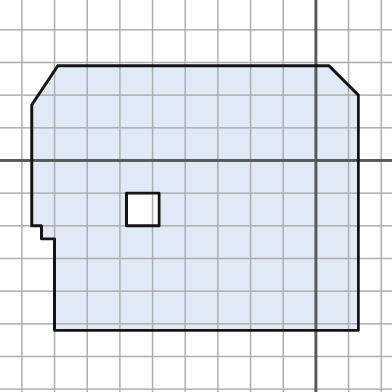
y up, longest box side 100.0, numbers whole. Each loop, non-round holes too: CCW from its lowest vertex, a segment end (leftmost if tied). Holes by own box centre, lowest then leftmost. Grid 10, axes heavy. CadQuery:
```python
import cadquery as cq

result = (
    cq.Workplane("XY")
    .moveTo(-80.0, -52.0)
    .lineTo(13.0, -52.0)
    .lineTo(13.0, 20.0)
    .lineTo(4.0, 29.0)
    .lineTo(-79.0, 29.0)
    .lineTo(-87.0, 17.0)
    .lineTo(-87.0, -20.0)
    .lineTo(-84.0, -20.0)
    .lineTo(-84.0, -24.0)
    .lineTo(-80.0, -24.0)
    .close()
    .moveTo(-58.0, -20.0)
    .lineTo(-48.0, -20.0)
    .lineTo(-48.0, -10.0)
    .lineTo(-58.0, -10.0)
    .close()
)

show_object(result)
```